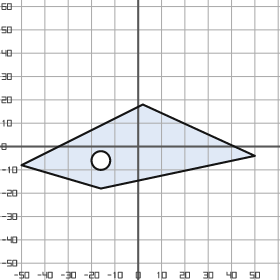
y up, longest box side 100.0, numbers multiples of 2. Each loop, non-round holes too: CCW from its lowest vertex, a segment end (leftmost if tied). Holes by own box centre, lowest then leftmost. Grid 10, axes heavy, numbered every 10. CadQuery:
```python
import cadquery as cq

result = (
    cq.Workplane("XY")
    .moveTo(-16.0, -18.0)
    .lineTo(50.0, -4.0)
    .lineTo(2.0, 18.0)
    .lineTo(-50.0, -8.0)
    .close()
    .moveTo(-16.0, -6.0)
    .circle(4.0)
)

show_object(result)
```